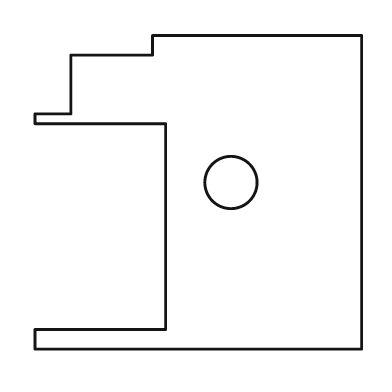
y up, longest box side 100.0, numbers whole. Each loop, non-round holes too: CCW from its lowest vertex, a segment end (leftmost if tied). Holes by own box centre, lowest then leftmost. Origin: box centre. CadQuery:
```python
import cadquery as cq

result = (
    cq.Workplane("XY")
    .moveTo(-50.0, -48.0)
    .lineTo(50.0, -48.0)
    .lineTo(50.0, 48.0)
    .lineTo(-14.0, 48.0)
    .lineTo(-14.0, 42.0)
    .lineTo(-39.0, 42.0)
    .lineTo(-39.0, 24.0)
    .lineTo(-50.0, 24.0)
    .lineTo(-50.0, 21.0)
    .lineTo(-10.0, 21.0)
    .lineTo(-10.0, -42.0)
    .lineTo(-50.0, -42.0)
    .close()
    .moveTo(10.0, 3.0)
    .circle(8.0)
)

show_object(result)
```